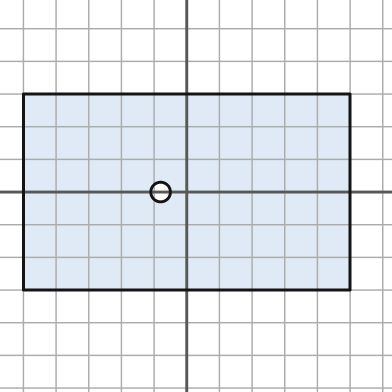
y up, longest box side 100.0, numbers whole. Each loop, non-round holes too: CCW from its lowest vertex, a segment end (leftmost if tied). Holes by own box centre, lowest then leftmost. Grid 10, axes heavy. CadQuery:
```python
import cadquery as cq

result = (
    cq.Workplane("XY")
    .moveTo(-50.0, -30.0)
    .lineTo(50.0, -30.0)
    .lineTo(50.0, 30.0)
    .lineTo(-50.0, 30.0)
    .close()
    .moveTo(-8.0, 0.0)
    .circle(3.0)
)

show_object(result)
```